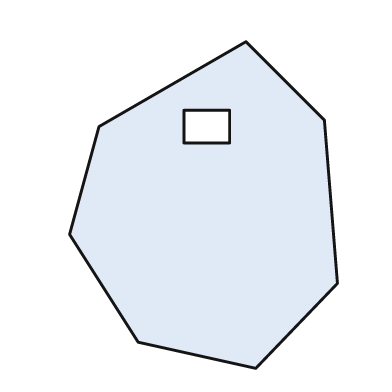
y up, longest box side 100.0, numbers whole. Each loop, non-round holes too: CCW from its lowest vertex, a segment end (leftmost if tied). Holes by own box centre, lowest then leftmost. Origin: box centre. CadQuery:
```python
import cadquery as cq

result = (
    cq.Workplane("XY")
    .moveTo(16.0, -50.0)
    .lineTo(41.0, -24.0)
    .lineTo(37.0, 26.0)
    .lineTo(13.0, 50.0)
    .lineTo(-32.0, 24.0)
    .lineTo(-41.0, -9.0)
    .lineTo(-20.0, -42.0)
    .close()
    .moveTo(-6.0, 19.0)
    .lineTo(8.0, 19.0)
    .lineTo(8.0, 29.0)
    .lineTo(-6.0, 29.0)
    .close()
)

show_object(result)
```